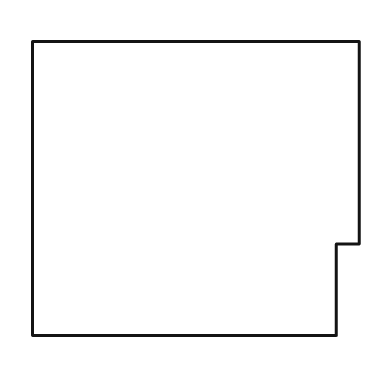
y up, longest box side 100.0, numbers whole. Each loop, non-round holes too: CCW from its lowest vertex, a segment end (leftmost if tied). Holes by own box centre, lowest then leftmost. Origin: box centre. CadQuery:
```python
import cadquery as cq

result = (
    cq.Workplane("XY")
    .moveTo(-50.0, -45.0)
    .lineTo(43.0, -45.0)
    .lineTo(43.0, -17.0)
    .lineTo(50.0, -17.0)
    .lineTo(50.0, 45.0)
    .lineTo(-50.0, 45.0)
    .close()
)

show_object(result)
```